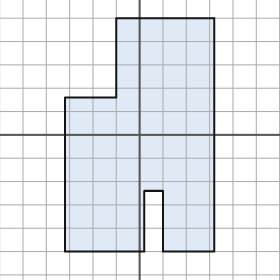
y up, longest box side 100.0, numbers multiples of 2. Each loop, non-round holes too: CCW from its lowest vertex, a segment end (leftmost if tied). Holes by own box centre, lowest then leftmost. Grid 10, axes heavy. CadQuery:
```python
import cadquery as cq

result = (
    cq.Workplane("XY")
    .moveTo(-32.0, -50.0)
    .lineTo(2.0, -50.0)
    .lineTo(2.0, -24.0)
    .lineTo(10.0, -24.0)
    .lineTo(10.0, -50.0)
    .lineTo(32.0, -50.0)
    .lineTo(32.0, 50.0)
    .lineTo(-10.0, 50.0)
    .lineTo(-10.0, 16.0)
    .lineTo(-32.0, 16.0)
    .close()
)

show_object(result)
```